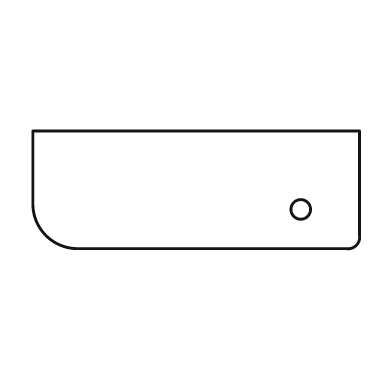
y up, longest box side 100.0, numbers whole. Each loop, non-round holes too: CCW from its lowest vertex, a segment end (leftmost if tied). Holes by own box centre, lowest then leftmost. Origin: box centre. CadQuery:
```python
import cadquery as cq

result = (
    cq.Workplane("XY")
    .moveTo(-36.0, -18.0)
    .lineTo(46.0, -18.0)
    .threePointArc((49.0, -17.0), (50.0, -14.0))
    .lineTo(50.0, 18.0)
    .lineTo(-50.0, 18.0)
    .lineTo(-50.0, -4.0)
    .threePointArc((-46.0, -14.0), (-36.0, -18.0))
    .close()
    .moveTo(32.0, -6.0)
    .circle(3.0)
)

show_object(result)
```